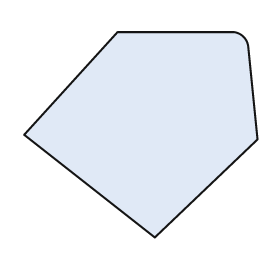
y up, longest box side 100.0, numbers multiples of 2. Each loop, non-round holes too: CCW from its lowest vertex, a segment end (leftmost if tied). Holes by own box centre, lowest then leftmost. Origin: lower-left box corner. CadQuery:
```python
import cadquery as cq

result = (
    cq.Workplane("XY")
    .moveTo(56.0, 0.0)
    .lineTo(100.0, 42.0)
    .lineTo(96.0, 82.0)
    .threePointArc((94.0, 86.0), (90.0, 88.0))
    .lineTo(40.0, 88.0)
    .lineTo(0.0, 44.0)
    .close()
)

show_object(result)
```